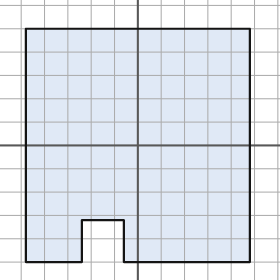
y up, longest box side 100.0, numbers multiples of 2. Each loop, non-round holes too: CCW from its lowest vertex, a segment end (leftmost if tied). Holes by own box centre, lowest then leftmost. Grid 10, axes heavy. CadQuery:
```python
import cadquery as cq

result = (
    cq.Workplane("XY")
    .moveTo(-48.0, -50.0)
    .lineTo(-24.0, -50.0)
    .lineTo(-24.0, -32.0)
    .lineTo(-6.0, -32.0)
    .lineTo(-6.0, -50.0)
    .lineTo(48.0, -50.0)
    .lineTo(48.0, 50.0)
    .lineTo(-48.0, 50.0)
    .close()
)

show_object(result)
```